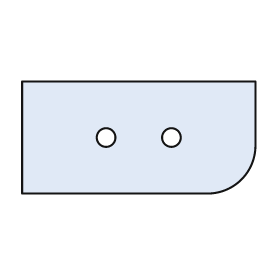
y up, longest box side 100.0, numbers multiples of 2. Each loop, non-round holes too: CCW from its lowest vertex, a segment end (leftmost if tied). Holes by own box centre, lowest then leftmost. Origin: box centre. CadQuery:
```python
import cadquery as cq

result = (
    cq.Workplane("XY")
    .moveTo(-50.0, -24.0)
    .lineTo(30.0, -24.0)
    .threePointArc((44.0, -18.0), (50.0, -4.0))
    .lineTo(50.0, 24.0)
    .lineTo(-50.0, 24.0)
    .close()
    .moveTo(-14.0, 0.0)
    .circle(4.0)
    .moveTo(14.0, 0.0)
    .circle(4.0)
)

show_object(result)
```